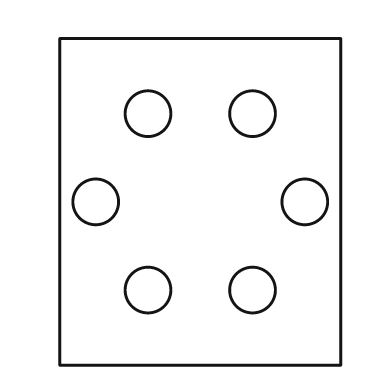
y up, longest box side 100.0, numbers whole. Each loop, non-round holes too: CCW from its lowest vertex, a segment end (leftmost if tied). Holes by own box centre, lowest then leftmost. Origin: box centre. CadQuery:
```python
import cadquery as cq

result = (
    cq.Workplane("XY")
    .moveTo(-43.0, -50.0)
    .lineTo(43.0, -50.0)
    .lineTo(43.0, 50.0)
    .lineTo(-43.0, 50.0)
    .close()
    .moveTo(-16.0, -27.0)
    .circle(7.0)
    .moveTo(16.0, -27.0)
    .circle(7.0)
    .moveTo(-32.0, 0.0)
    .circle(7.0)
    .moveTo(32.0, 0.0)
    .circle(7.0)
    .moveTo(-16.0, 27.0)
    .circle(7.0)
    .moveTo(16.0, 27.0)
    .circle(7.0)
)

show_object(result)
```